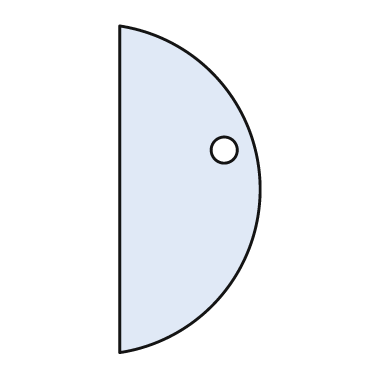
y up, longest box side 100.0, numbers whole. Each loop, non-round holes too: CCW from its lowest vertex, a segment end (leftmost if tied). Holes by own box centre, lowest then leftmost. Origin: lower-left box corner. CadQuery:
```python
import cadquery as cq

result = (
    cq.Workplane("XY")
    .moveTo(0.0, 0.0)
    .threePointArc((43.0, 50.0), (0.0, 100.0))
    .close()
    .moveTo(32.0, 62.0)
    .circle(4.0)
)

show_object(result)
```